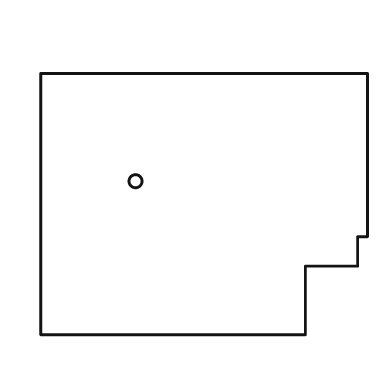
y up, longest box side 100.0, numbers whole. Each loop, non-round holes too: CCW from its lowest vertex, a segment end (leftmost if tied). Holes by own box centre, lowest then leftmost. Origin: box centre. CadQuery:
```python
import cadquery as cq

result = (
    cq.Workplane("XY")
    .moveTo(-50.0, -40.0)
    .lineTo(31.0, -40.0)
    .lineTo(31.0, -19.0)
    .lineTo(47.0, -19.0)
    .lineTo(47.0, -10.0)
    .lineTo(50.0, -10.0)
    .lineTo(50.0, 40.0)
    .lineTo(-50.0, 40.0)
    .close()
    .moveTo(-21.0, 7.0)
    .circle(2.0)
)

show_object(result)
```